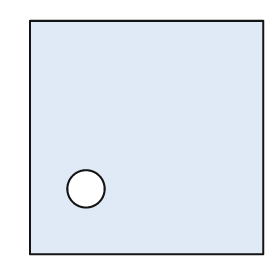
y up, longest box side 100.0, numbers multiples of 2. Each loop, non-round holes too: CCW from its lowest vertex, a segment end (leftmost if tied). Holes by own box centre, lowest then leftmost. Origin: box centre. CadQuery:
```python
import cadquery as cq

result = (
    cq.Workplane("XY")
    .moveTo(-50.0, -50.0)
    .lineTo(50.0, -50.0)
    .lineTo(50.0, 50.0)
    .lineTo(-50.0, 50.0)
    .close()
    .moveTo(-26.0, -22.0)
    .circle(8.0)
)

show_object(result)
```